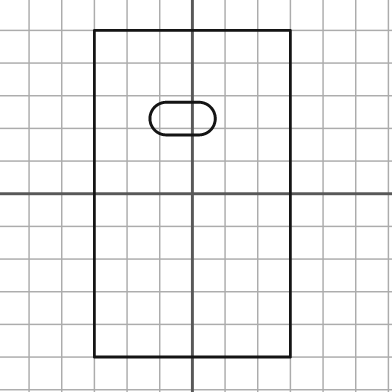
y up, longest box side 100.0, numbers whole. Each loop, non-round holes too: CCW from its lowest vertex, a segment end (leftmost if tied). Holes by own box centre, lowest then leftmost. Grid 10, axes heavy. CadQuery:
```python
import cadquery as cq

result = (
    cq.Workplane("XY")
    .moveTo(-30.0, -50.0)
    .lineTo(30.0, -50.0)
    .lineTo(30.0, 50.0)
    .lineTo(-30.0, 50.0)
    .close()
    .moveTo(-8.0, 18.0)
    .lineTo(2.0, 18.0)
    .threePointArc((7.0, 23.0), (2.0, 28.0))
    .lineTo(-8.0, 28.0)
    .threePointArc((-13.0, 23.0), (-8.0, 18.0))
    .close()
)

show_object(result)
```